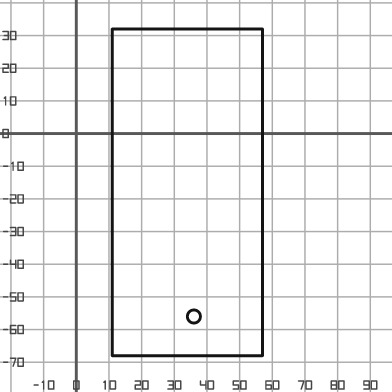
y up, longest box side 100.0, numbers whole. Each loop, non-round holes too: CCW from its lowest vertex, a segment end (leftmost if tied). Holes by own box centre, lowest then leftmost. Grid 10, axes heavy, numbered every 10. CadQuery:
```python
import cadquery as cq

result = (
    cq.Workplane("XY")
    .moveTo(11.0, -68.0)
    .lineTo(57.0, -68.0)
    .lineTo(57.0, 32.0)
    .lineTo(11.0, 32.0)
    .close()
    .moveTo(36.0, -56.0)
    .circle(2.0)
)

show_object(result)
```